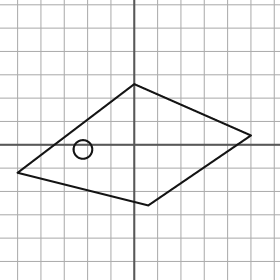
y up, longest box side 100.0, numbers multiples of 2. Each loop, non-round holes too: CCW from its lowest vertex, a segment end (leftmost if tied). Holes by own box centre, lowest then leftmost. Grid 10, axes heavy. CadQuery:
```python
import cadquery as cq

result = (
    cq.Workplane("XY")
    .moveTo(6.0, -26.0)
    .lineTo(50.0, 4.0)
    .lineTo(0.0, 26.0)
    .lineTo(-50.0, -12.0)
    .close()
    .moveTo(-22.0, -2.0)
    .circle(4.0)
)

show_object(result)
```